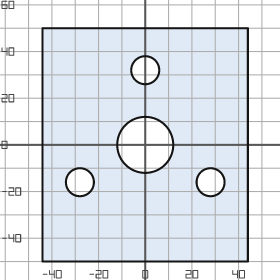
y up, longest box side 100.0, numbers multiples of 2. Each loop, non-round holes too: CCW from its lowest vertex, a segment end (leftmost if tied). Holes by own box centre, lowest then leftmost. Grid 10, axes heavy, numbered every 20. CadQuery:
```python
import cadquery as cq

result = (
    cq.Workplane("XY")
    .moveTo(-44.0, -50.0)
    .lineTo(44.0, -50.0)
    .lineTo(44.0, 50.0)
    .lineTo(-44.0, 50.0)
    .close()
    .moveTo(-28.0, -16.0)
    .circle(6.0)
    .moveTo(28.0, -16.0)
    .circle(6.0)
    .moveTo(0.0, 0.0)
    .circle(12.0)
    .moveTo(0.0, 32.0)
    .circle(6.0)
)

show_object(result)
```